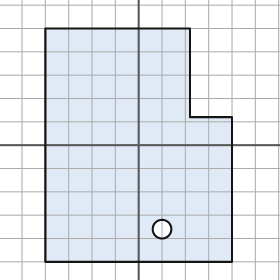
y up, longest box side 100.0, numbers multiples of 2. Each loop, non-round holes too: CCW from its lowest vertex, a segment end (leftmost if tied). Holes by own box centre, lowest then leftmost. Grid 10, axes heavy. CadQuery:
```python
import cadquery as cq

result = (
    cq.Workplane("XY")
    .moveTo(-40.0, -50.0)
    .lineTo(40.0, -50.0)
    .lineTo(40.0, 12.0)
    .lineTo(22.0, 12.0)
    .lineTo(22.0, 50.0)
    .lineTo(-40.0, 50.0)
    .close()
    .moveTo(10.0, -36.0)
    .circle(4.0)
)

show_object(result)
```